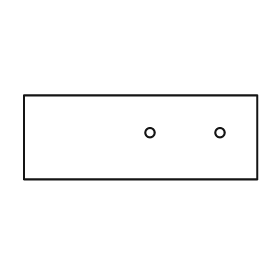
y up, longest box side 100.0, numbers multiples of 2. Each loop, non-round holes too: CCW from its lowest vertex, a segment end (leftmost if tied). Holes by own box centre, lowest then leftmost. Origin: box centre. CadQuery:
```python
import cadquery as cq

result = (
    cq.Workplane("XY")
    .moveTo(-50.0, -18.0)
    .lineTo(50.0, -18.0)
    .lineTo(50.0, 18.0)
    .lineTo(-50.0, 18.0)
    .close()
    .moveTo(4.0, 2.0)
    .circle(2.0)
    .moveTo(34.0, 2.0)
    .circle(2.0)
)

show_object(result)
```